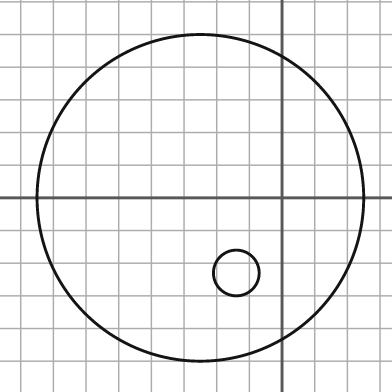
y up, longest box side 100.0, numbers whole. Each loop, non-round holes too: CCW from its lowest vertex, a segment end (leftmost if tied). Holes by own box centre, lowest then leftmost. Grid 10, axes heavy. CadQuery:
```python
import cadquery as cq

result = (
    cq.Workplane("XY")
    .moveTo(-25.0, 0.0)
    .circle(50.0)
    .moveTo(-14.0, -23.0)
    .circle(7.0)
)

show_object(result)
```